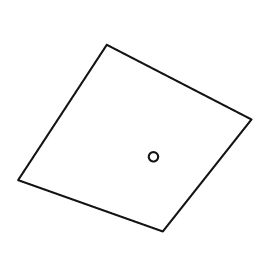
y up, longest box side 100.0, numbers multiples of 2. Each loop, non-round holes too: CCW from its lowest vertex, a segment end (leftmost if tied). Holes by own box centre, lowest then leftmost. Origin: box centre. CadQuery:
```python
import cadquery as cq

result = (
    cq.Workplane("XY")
    .moveTo(12.0, -40.0)
    .lineTo(50.0, 8.0)
    .lineTo(-12.0, 40.0)
    .lineTo(-50.0, -18.0)
    .close()
    .moveTo(8.0, -8.0)
    .circle(2.0)
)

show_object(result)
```